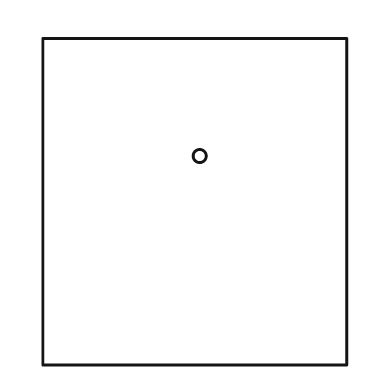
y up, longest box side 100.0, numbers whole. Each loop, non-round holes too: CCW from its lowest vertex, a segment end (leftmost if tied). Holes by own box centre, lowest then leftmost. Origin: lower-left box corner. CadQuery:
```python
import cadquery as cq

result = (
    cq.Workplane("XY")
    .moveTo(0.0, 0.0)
    .lineTo(93.0, 0.0)
    .lineTo(93.0, 100.0)
    .lineTo(0.0, 100.0)
    .close()
    .moveTo(48.0, 64.0)
    .circle(2.0)
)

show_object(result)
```